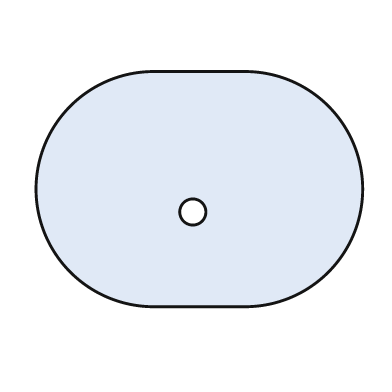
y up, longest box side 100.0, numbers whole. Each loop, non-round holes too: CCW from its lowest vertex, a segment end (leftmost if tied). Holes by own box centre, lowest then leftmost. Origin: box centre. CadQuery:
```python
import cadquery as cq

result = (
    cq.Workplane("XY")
    .moveTo(-14.0, -36.0)
    .lineTo(14.0, -36.0)
    .threePointArc((50.0, 0.0), (14.0, 36.0))
    .lineTo(-14.0, 36.0)
    .threePointArc((-50.0, 0.0), (-14.0, -36.0))
    .close()
    .moveTo(-2.0, -7.0)
    .circle(4.0)
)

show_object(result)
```